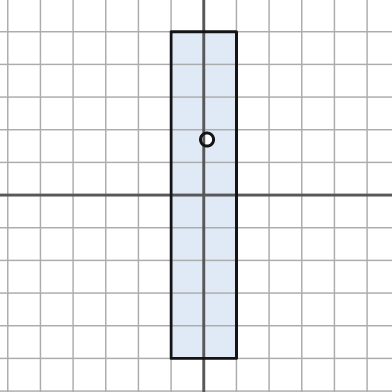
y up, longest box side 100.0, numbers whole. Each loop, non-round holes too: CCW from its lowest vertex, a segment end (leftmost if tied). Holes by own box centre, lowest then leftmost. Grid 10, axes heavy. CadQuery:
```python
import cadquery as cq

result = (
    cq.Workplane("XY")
    .moveTo(-10.0, -50.0)
    .lineTo(10.0, -50.0)
    .lineTo(10.0, 50.0)
    .lineTo(-10.0, 50.0)
    .close()
    .moveTo(1.0, 17.0)
    .circle(2.0)
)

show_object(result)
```